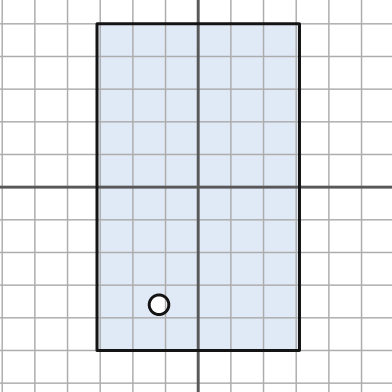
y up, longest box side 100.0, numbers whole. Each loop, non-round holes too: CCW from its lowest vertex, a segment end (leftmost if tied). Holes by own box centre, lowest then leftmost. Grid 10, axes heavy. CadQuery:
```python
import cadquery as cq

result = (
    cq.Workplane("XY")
    .moveTo(-31.0, -50.0)
    .lineTo(31.0, -50.0)
    .lineTo(31.0, 50.0)
    .lineTo(-31.0, 50.0)
    .close()
    .moveTo(-12.0, -36.0)
    .circle(3.0)
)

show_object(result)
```